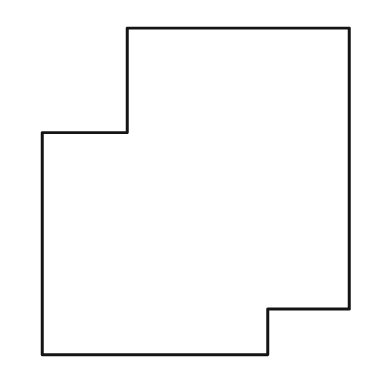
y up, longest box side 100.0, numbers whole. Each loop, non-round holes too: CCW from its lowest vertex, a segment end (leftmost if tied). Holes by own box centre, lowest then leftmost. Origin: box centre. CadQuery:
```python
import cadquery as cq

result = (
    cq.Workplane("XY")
    .moveTo(-47.0, -50.0)
    .lineTo(22.0, -50.0)
    .lineTo(22.0, -36.0)
    .lineTo(47.0, -36.0)
    .lineTo(47.0, 50.0)
    .lineTo(-21.0, 50.0)
    .lineTo(-21.0, 18.0)
    .lineTo(-47.0, 18.0)
    .close()
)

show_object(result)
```